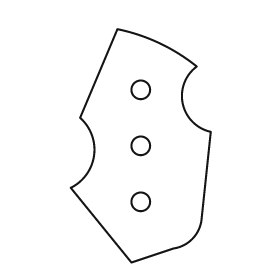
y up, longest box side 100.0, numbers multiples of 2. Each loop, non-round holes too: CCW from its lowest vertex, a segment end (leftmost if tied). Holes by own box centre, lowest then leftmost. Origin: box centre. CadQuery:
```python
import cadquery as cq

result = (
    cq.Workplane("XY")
    .moveTo(-4.0, -50.0)
    .lineTo(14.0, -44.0)
    .threePointArc((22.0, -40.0), (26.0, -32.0))
    .lineTo(30.0, 6.0)
    .threePointArc((18.0, 18.0), (24.0, 34.0))
    .threePointArc((8.0, 44.0), (-10.0, 50.0))
    .lineTo(-26.0, 12.0)
    .threePointArc((-20.0, -4.0), (-30.0, -18.0))
    .close()
    .moveTo(0.0, -24.0)
    .circle(4.0)
    .moveTo(0.0, 0.0)
    .circle(4.0)
    .moveTo(0.0, 24.0)
    .circle(4.0)
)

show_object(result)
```